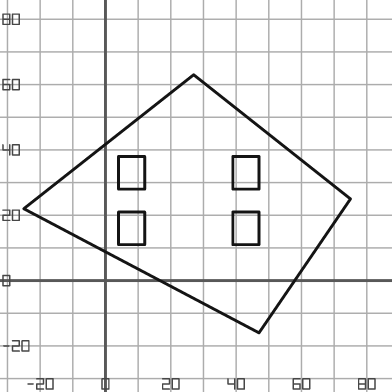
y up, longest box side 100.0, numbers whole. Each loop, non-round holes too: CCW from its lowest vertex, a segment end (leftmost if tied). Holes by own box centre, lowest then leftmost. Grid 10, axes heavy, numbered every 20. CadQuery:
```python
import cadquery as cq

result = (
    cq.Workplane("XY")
    .moveTo(47.0, -16.0)
    .lineTo(75.0, 25.0)
    .lineTo(27.0, 63.0)
    .lineTo(-25.0, 22.0)
    .close()
    .moveTo(4.0, 11.0)
    .lineTo(12.0, 11.0)
    .lineTo(12.0, 21.0)
    .lineTo(4.0, 21.0)
    .close()
    .moveTo(39.0, 11.0)
    .lineTo(47.0, 11.0)
    .lineTo(47.0, 21.0)
    .lineTo(39.0, 21.0)
    .close()
    .moveTo(4.0, 28.0)
    .lineTo(12.0, 28.0)
    .lineTo(12.0, 38.0)
    .lineTo(4.0, 38.0)
    .close()
    .moveTo(39.0, 28.0)
    .lineTo(47.0, 28.0)
    .lineTo(47.0, 38.0)
    .lineTo(39.0, 38.0)
    .close()
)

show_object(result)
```